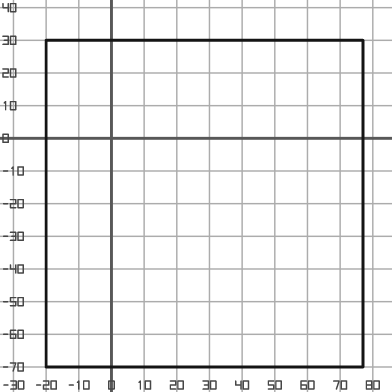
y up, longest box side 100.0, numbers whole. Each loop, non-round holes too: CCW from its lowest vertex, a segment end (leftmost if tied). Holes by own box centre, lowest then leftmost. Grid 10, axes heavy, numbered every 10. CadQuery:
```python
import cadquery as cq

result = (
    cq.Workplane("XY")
    .moveTo(-20.0, -70.0)
    .lineTo(77.0, -70.0)
    .lineTo(77.0, 30.0)
    .lineTo(-20.0, 30.0)
    .close()
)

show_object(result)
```